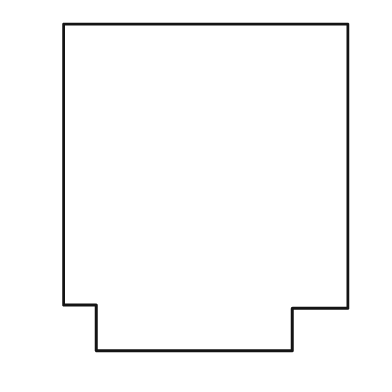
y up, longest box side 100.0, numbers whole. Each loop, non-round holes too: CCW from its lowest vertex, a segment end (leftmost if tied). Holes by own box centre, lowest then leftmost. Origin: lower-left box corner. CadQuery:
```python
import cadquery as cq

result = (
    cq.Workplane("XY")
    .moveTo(10.0, 0.0)
    .lineTo(70.0, 0.0)
    .lineTo(70.0, 13.0)
    .lineTo(87.0, 13.0)
    .lineTo(87.0, 100.0)
    .lineTo(0.0, 100.0)
    .lineTo(0.0, 14.0)
    .lineTo(10.0, 14.0)
    .close()
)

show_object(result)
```